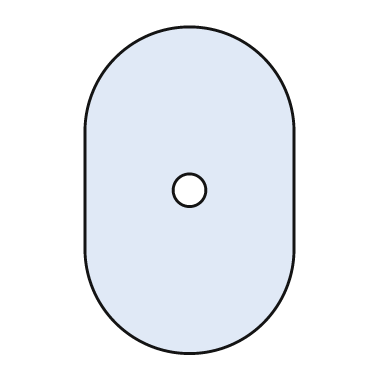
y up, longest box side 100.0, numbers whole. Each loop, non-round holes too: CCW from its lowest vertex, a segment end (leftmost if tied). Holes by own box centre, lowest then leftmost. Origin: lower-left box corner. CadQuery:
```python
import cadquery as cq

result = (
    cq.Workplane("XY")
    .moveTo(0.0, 32.0)
    .threePointArc((32.0, 0.0), (64.0, 32.0))
    .lineTo(64.0, 68.0)
    .threePointArc((32.0, 100.0), (0.0, 68.0))
    .close()
    .moveTo(32.0, 50.0)
    .circle(5.0)
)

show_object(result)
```